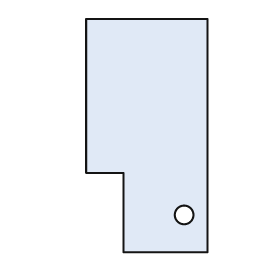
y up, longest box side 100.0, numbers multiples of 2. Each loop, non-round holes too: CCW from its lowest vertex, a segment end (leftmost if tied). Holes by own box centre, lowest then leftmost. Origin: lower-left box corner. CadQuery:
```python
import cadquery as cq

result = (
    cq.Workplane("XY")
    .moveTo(16.0, 0.0)
    .lineTo(52.0, 0.0)
    .lineTo(52.0, 100.0)
    .lineTo(0.0, 100.0)
    .lineTo(0.0, 34.0)
    .lineTo(16.0, 34.0)
    .close()
    .moveTo(42.0, 16.0)
    .circle(4.0)
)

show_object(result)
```